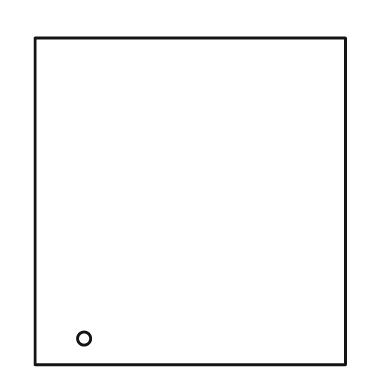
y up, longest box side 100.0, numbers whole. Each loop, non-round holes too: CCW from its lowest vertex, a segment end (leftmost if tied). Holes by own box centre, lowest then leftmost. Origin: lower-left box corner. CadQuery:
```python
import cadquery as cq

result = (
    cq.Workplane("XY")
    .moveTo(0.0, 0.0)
    .lineTo(95.0, 0.0)
    .lineTo(95.0, 100.0)
    .lineTo(0.0, 100.0)
    .close()
    .moveTo(15.0, 8.0)
    .circle(2.0)
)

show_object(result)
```